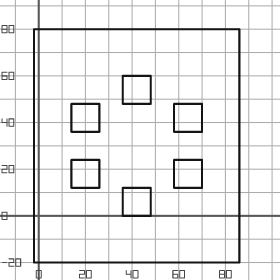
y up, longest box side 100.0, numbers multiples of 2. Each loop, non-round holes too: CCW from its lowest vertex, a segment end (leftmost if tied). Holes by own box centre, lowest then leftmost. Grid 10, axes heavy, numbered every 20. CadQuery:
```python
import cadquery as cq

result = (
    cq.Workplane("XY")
    .moveTo(-2.0, -20.0)
    .lineTo(86.0, -20.0)
    .lineTo(86.0, 80.0)
    .lineTo(-2.0, 80.0)
    .close()
    .moveTo(36.0, 0.0)
    .lineTo(48.0, 0.0)
    .lineTo(48.0, 12.0)
    .lineTo(36.0, 12.0)
    .close()
    .moveTo(14.0, 12.0)
    .lineTo(26.0, 12.0)
    .lineTo(26.0, 24.0)
    .lineTo(14.0, 24.0)
    .close()
    .moveTo(58.0, 12.0)
    .lineTo(70.0, 12.0)
    .lineTo(70.0, 24.0)
    .lineTo(58.0, 24.0)
    .close()
    .moveTo(14.0, 36.0)
    .lineTo(26.0, 36.0)
    .lineTo(26.0, 48.0)
    .lineTo(14.0, 48.0)
    .close()
    .moveTo(58.0, 36.0)
    .lineTo(70.0, 36.0)
    .lineTo(70.0, 48.0)
    .lineTo(58.0, 48.0)
    .close()
    .moveTo(36.0, 48.0)
    .lineTo(48.0, 48.0)
    .lineTo(48.0, 60.0)
    .lineTo(36.0, 60.0)
    .close()
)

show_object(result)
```